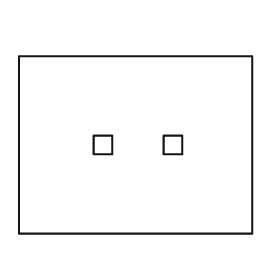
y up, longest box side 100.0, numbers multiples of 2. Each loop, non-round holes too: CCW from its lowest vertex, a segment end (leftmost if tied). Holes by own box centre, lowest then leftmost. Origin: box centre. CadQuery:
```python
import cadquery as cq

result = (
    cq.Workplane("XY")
    .moveTo(-50.0, -38.0)
    .lineTo(50.0, -38.0)
    .lineTo(50.0, 38.0)
    .lineTo(-50.0, 38.0)
    .close()
    .moveTo(-18.0, -4.0)
    .lineTo(-10.0, -4.0)
    .lineTo(-10.0, 4.0)
    .lineTo(-18.0, 4.0)
    .close()
    .moveTo(12.0, -4.0)
    .lineTo(20.0, -4.0)
    .lineTo(20.0, 4.0)
    .lineTo(12.0, 4.0)
    .close()
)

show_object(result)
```